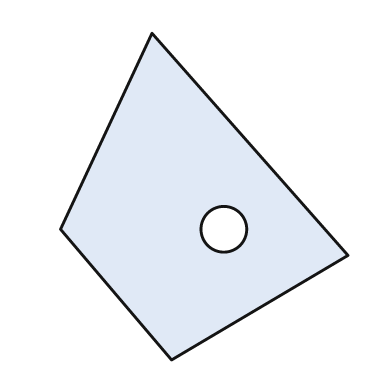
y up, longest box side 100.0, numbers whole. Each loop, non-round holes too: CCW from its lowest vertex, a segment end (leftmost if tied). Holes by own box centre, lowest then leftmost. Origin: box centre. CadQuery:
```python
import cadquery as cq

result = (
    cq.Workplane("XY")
    .moveTo(-10.0, -50.0)
    .lineTo(44.0, -18.0)
    .lineTo(-16.0, 50.0)
    .lineTo(-44.0, -10.0)
    .close()
    .moveTo(6.0, -10.0)
    .circle(7.0)
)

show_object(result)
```